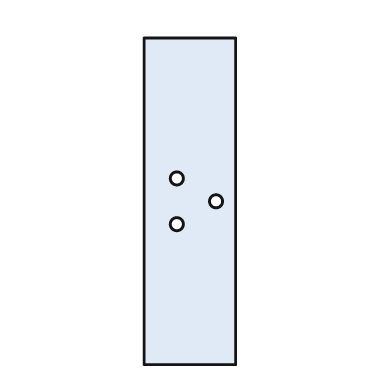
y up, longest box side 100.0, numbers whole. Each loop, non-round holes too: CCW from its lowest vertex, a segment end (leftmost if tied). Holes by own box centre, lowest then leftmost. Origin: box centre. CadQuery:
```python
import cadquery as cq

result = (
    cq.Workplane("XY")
    .moveTo(-14.0, -50.0)
    .lineTo(14.0, -50.0)
    .lineTo(14.0, 50.0)
    .lineTo(-14.0, 50.0)
    .close()
    .moveTo(-4.0, -7.0)
    .circle(2.0)
    .moveTo(8.0, 0.0)
    .circle(2.0)
    .moveTo(-4.0, 7.0)
    .circle(2.0)
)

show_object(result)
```